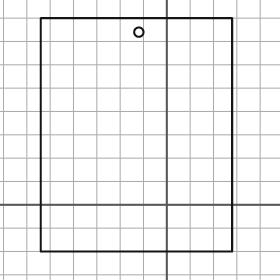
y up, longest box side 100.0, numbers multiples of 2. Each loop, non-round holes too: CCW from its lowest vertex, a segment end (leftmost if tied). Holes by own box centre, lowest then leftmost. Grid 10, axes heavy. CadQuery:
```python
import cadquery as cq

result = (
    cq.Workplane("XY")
    .moveTo(-54.0, -20.0)
    .lineTo(28.0, -20.0)
    .lineTo(28.0, 80.0)
    .lineTo(-54.0, 80.0)
    .close()
    .moveTo(-12.0, 74.0)
    .circle(2.0)
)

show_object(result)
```